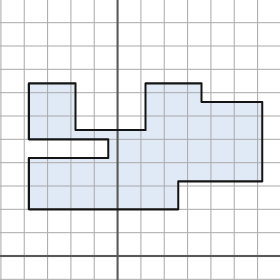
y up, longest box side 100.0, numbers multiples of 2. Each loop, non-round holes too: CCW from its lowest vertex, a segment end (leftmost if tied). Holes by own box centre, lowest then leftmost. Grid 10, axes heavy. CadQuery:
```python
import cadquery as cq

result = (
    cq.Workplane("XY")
    .moveTo(-38.0, 20.0)
    .lineTo(26.0, 20.0)
    .lineTo(26.0, 32.0)
    .lineTo(62.0, 32.0)
    .lineTo(62.0, 66.0)
    .lineTo(36.0, 66.0)
    .lineTo(36.0, 74.0)
    .lineTo(12.0, 74.0)
    .lineTo(12.0, 54.0)
    .lineTo(-18.0, 54.0)
    .lineTo(-18.0, 74.0)
    .lineTo(-38.0, 74.0)
    .lineTo(-38.0, 50.0)
    .lineTo(-4.0, 50.0)
    .lineTo(-4.0, 42.0)
    .lineTo(-38.0, 42.0)
    .close()
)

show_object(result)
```